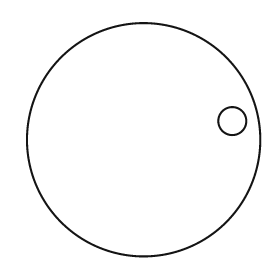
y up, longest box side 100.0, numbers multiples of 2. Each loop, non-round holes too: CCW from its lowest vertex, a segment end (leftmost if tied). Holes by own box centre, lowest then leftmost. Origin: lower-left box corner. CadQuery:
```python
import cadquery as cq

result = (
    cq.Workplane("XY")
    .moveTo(50.0, 50.0)
    .circle(50.0)
    .moveTo(88.0, 58.0)
    .circle(6.0)
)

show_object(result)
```